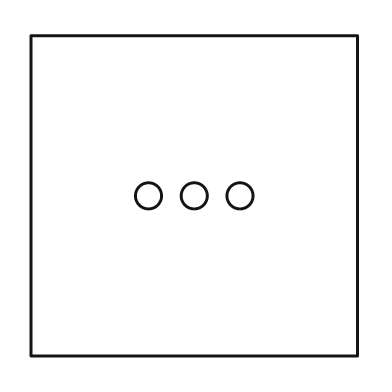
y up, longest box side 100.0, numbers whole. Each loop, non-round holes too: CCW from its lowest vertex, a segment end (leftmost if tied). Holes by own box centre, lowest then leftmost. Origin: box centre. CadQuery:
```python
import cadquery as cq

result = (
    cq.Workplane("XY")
    .moveTo(-50.0, -49.0)
    .lineTo(50.0, -49.0)
    .lineTo(50.0, 49.0)
    .lineTo(-50.0, 49.0)
    .close()
    .moveTo(-14.0, 0.0)
    .circle(4.0)
    .moveTo(0.0, 0.0)
    .circle(4.0)
    .moveTo(14.0, 0.0)
    .circle(4.0)
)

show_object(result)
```